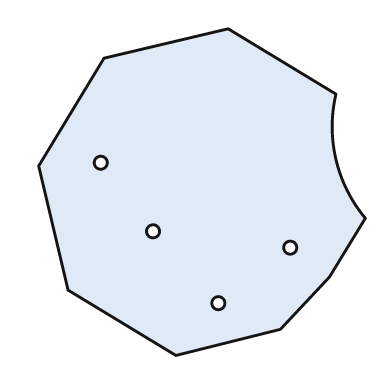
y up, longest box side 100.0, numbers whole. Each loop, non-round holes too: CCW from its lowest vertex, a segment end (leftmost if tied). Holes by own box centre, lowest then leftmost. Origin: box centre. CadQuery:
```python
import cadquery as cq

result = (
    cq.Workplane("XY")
    .moveTo(-8.0, -50.0)
    .lineTo(24.0, -42.0)
    .lineTo(39.0, -26.0)
    .lineTo(50.0, -8.0)
    .threePointArc((41.0, 10.0), (41.0, 30.0))
    .lineTo(8.0, 50.0)
    .lineTo(-30.0, 41.0)
    .lineTo(-50.0, 8.0)
    .lineTo(-41.0, -30.0)
    .close()
    .moveTo(5.0, -34.0)
    .circle(2.0)
    .moveTo(27.0, -17.0)
    .circle(2.0)
    .moveTo(-15.0, -12.0)
    .circle(2.0)
    .moveTo(-31.0, 9.0)
    .circle(2.0)
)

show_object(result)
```